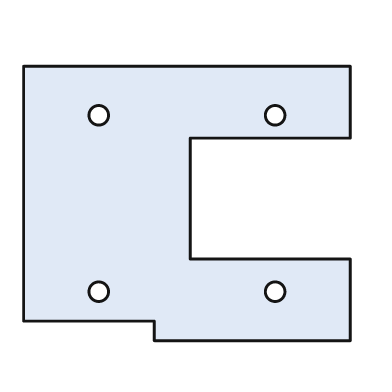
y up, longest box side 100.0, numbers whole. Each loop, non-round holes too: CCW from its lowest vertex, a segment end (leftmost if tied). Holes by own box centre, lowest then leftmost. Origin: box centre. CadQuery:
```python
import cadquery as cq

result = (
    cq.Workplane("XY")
    .moveTo(-10.0, -42.0)
    .lineTo(50.0, -42.0)
    .lineTo(50.0, -17.0)
    .lineTo(1.0, -17.0)
    .lineTo(1.0, 20.0)
    .lineTo(50.0, 20.0)
    .lineTo(50.0, 42.0)
    .lineTo(-50.0, 42.0)
    .lineTo(-50.0, -36.0)
    .lineTo(-10.0, -36.0)
    .close()
    .moveTo(-27.0, -27.0)
    .circle(3.0)
    .moveTo(27.0, -27.0)
    .circle(3.0)
    .moveTo(-27.0, 27.0)
    .circle(3.0)
    .moveTo(27.0, 27.0)
    .circle(3.0)
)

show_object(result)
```